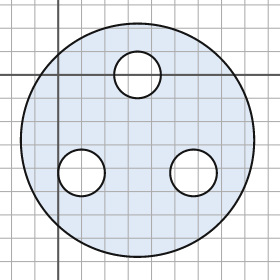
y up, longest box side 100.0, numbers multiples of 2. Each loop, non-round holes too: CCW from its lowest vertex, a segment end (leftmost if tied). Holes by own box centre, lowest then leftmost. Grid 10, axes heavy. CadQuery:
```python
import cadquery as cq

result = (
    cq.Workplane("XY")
    .moveTo(34.0, -28.0)
    .circle(50.0)
    .moveTo(10.0, -42.0)
    .circle(10.0)
    .moveTo(58.0, -42.0)
    .circle(10.0)
    .moveTo(34.0, 0.0)
    .circle(10.0)
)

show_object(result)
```